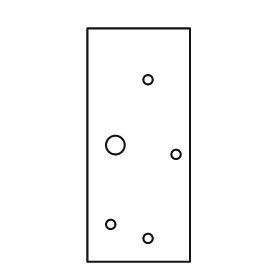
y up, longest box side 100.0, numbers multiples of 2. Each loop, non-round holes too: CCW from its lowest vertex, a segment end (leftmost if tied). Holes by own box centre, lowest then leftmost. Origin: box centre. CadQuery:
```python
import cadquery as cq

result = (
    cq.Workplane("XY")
    .moveTo(-22.0, -50.0)
    .lineTo(22.0, -50.0)
    .lineTo(22.0, 50.0)
    .lineTo(-22.0, 50.0)
    .close()
    .moveTo(4.0, -40.0)
    .circle(2.0)
    .moveTo(-12.0, -34.0)
    .circle(2.0)
    .moveTo(16.0, -4.0)
    .circle(2.0)
    .moveTo(-10.0, 0.0)
    .circle(4.0)
    .moveTo(4.0, 28.0)
    .circle(2.0)
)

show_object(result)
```